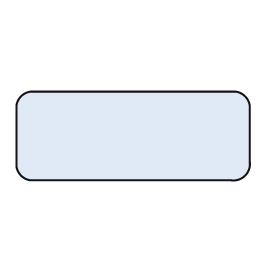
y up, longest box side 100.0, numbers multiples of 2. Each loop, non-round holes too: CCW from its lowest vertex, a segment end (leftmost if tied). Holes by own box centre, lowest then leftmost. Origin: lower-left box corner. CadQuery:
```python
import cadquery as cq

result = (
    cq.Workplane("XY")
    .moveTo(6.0, 0.0)
    .lineTo(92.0, 0.0)
    .threePointArc((98.0, 2.0), (100.0, 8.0))
    .lineTo(100.0, 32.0)
    .threePointArc((98.0, 36.0), (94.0, 38.0))
    .lineTo(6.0, 38.0)
    .threePointArc((2.0, 36.0), (0.0, 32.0))
    .lineTo(0.0, 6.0)
    .threePointArc((2.0, 2.0), (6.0, 0.0))
    .close()
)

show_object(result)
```